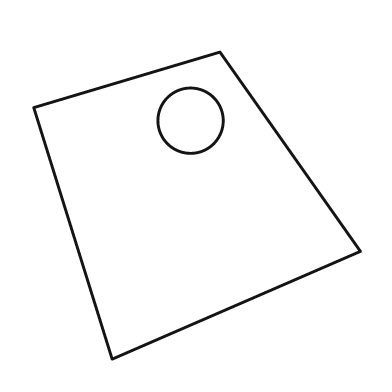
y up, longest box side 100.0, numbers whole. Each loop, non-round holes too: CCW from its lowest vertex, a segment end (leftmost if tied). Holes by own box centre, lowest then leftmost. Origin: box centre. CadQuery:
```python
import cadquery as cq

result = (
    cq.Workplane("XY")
    .moveTo(-26.0, -47.0)
    .lineTo(50.0, -14.0)
    .lineTo(7.0, 47.0)
    .lineTo(-50.0, 30.0)
    .close()
    .moveTo(-2.0, 26.0)
    .circle(10.0)
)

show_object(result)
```